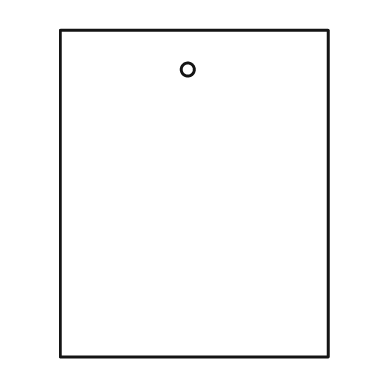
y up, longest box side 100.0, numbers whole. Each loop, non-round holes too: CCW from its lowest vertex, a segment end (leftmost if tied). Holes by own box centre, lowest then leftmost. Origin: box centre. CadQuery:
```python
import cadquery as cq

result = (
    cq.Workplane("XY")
    .moveTo(-41.0, -50.0)
    .lineTo(41.0, -50.0)
    .lineTo(41.0, 50.0)
    .lineTo(-41.0, 50.0)
    .close()
    .moveTo(-2.0, 38.0)
    .circle(2.0)
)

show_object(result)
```